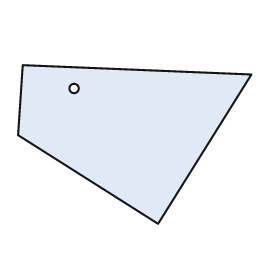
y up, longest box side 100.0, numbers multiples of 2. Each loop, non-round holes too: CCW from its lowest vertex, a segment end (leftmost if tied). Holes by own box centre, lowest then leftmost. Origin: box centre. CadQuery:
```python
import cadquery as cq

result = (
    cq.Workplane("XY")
    .moveTo(10.0, -34.0)
    .lineTo(50.0, 30.0)
    .lineTo(-48.0, 34.0)
    .lineTo(-50.0, 4.0)
    .close()
    .moveTo(-26.0, 24.0)
    .circle(2.0)
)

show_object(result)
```